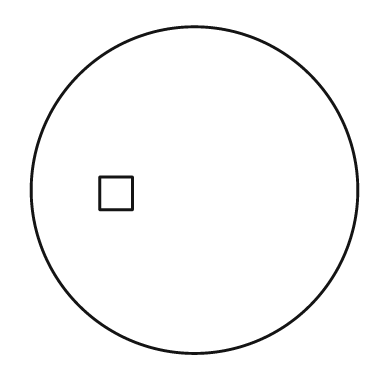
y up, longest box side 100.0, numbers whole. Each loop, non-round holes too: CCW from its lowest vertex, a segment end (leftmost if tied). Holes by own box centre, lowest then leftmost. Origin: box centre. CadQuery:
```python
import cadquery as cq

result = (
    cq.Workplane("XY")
    .moveTo(0.0, 0.0)
    .circle(50.0)
    .moveTo(-29.0, -6.0)
    .lineTo(-19.0, -6.0)
    .lineTo(-19.0, 4.0)
    .lineTo(-29.0, 4.0)
    .close()
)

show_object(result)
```